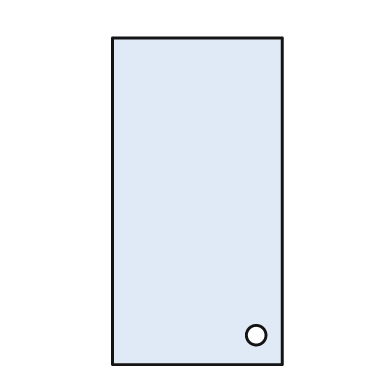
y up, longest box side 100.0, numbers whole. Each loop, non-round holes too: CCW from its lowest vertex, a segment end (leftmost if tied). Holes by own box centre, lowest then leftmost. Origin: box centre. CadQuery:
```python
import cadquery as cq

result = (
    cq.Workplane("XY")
    .moveTo(-26.0, -50.0)
    .lineTo(26.0, -50.0)
    .lineTo(26.0, 50.0)
    .lineTo(-26.0, 50.0)
    .close()
    .moveTo(18.0, -41.0)
    .circle(3.0)
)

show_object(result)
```